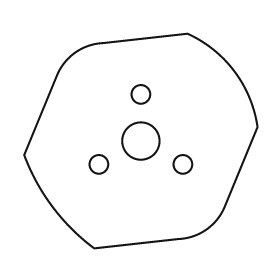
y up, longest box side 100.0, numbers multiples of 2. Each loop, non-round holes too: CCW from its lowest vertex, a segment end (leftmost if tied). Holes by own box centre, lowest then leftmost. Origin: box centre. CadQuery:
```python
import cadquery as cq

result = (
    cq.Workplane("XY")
    .moveTo(-20.0, -46.0)
    .lineTo(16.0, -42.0)
    .threePointArc((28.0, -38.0), (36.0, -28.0))
    .lineTo(50.0, 6.0)
    .threePointArc((40.0, 30.0), (20.0, 46.0))
    .lineTo(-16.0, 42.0)
    .threePointArc((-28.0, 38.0), (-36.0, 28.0))
    .lineTo(-50.0, -6.0)
    .threePointArc((-38.0, -28.0), (-20.0, -46.0))
    .close()
    .moveTo(-18.0, -10.0)
    .circle(4.0)
    .moveTo(18.0, -10.0)
    .circle(4.0)
    .moveTo(0.0, 0.0)
    .circle(8.0)
    .moveTo(0.0, 20.0)
    .circle(4.0)
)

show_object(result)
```